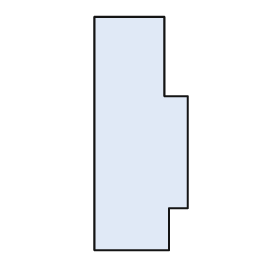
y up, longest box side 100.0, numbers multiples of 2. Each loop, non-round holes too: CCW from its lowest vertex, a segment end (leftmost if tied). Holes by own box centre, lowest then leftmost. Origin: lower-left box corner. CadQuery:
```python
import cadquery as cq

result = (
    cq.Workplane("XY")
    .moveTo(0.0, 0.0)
    .lineTo(32.0, 0.0)
    .lineTo(32.0, 18.0)
    .lineTo(40.0, 18.0)
    .lineTo(40.0, 66.0)
    .lineTo(30.0, 66.0)
    .lineTo(30.0, 100.0)
    .lineTo(0.0, 100.0)
    .close()
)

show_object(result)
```